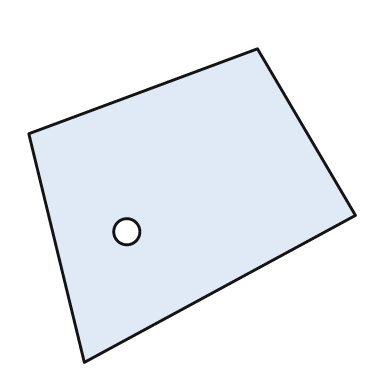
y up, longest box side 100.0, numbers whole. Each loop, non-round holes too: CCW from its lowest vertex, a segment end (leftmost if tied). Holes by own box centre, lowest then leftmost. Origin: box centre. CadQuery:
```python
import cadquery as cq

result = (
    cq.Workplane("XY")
    .moveTo(-33.0, -48.0)
    .lineTo(50.0, -3.0)
    .lineTo(20.0, 48.0)
    .lineTo(-50.0, 22.0)
    .close()
    .moveTo(-20.0, -8.0)
    .circle(4.0)
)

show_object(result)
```